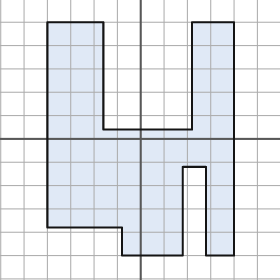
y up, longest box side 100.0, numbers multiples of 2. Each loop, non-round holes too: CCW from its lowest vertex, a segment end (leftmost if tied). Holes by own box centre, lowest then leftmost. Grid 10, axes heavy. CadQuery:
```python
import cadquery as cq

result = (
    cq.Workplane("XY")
    .moveTo(-8.0, -50.0)
    .lineTo(18.0, -50.0)
    .lineTo(18.0, -12.0)
    .lineTo(28.0, -12.0)
    .lineTo(28.0, -50.0)
    .lineTo(40.0, -50.0)
    .lineTo(40.0, 50.0)
    .lineTo(22.0, 50.0)
    .lineTo(22.0, 4.0)
    .lineTo(-16.0, 4.0)
    .lineTo(-16.0, 50.0)
    .lineTo(-40.0, 50.0)
    .lineTo(-40.0, -38.0)
    .lineTo(-8.0, -38.0)
    .close()
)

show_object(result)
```